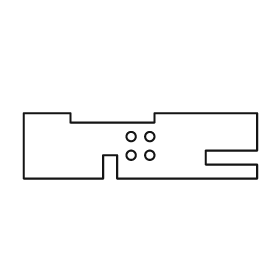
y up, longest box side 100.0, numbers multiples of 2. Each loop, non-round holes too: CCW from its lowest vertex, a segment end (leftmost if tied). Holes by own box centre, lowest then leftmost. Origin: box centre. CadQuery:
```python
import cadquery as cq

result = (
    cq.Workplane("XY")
    .moveTo(-50.0, -14.0)
    .lineTo(-16.0, -14.0)
    .lineTo(-16.0, -4.0)
    .lineTo(-10.0, -4.0)
    .lineTo(-10.0, -14.0)
    .lineTo(50.0, -14.0)
    .lineTo(50.0, -8.0)
    .lineTo(28.0, -8.0)
    .lineTo(28.0, -2.0)
    .lineTo(50.0, -2.0)
    .lineTo(50.0, 14.0)
    .lineTo(6.0, 14.0)
    .lineTo(6.0, 10.0)
    .lineTo(-30.0, 10.0)
    .lineTo(-30.0, 14.0)
    .lineTo(-50.0, 14.0)
    .close()
    .moveTo(-4.0, -4.0)
    .circle(2.0)
    .moveTo(4.0, -4.0)
    .circle(2.0)
    .moveTo(-4.0, 4.0)
    .circle(2.0)
    .moveTo(4.0, 4.0)
    .circle(2.0)
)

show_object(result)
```